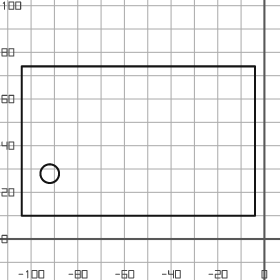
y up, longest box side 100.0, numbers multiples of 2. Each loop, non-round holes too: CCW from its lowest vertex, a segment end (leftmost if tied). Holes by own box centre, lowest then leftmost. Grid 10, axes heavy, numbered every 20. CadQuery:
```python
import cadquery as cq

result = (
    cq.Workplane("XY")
    .moveTo(-104.0, 10.0)
    .lineTo(-4.0, 10.0)
    .lineTo(-4.0, 74.0)
    .lineTo(-104.0, 74.0)
    .close()
    .moveTo(-92.0, 28.0)
    .circle(4.0)
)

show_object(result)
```